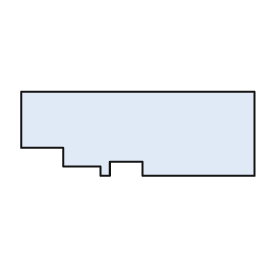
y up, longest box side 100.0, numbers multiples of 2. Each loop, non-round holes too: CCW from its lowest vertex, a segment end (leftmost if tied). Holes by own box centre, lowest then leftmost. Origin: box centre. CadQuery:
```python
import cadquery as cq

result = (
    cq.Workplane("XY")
    .moveTo(-16.0, -18.0)
    .lineTo(-12.0, -18.0)
    .lineTo(-12.0, -12.0)
    .lineTo(2.0, -12.0)
    .lineTo(2.0, -18.0)
    .lineTo(50.0, -18.0)
    .lineTo(50.0, 18.0)
    .lineTo(-50.0, 18.0)
    .lineTo(-50.0, -6.0)
    .lineTo(-32.0, -6.0)
    .lineTo(-32.0, -14.0)
    .lineTo(-16.0, -14.0)
    .close()
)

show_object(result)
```